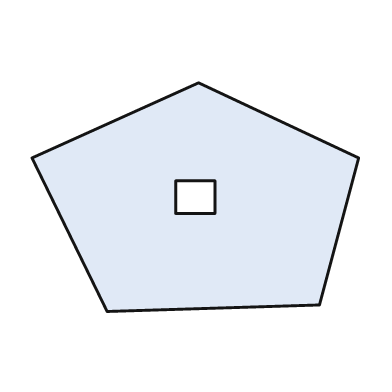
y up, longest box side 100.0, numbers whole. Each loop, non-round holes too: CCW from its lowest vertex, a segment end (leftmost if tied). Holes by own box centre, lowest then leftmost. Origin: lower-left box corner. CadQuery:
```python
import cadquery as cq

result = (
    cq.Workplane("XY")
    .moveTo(23.0, 0.0)
    .lineTo(88.0, 2.0)
    .lineTo(100.0, 47.0)
    .lineTo(51.0, 70.0)
    .lineTo(0.0, 47.0)
    .close()
    .moveTo(44.0, 30.0)
    .lineTo(56.0, 30.0)
    .lineTo(56.0, 40.0)
    .lineTo(44.0, 40.0)
    .close()
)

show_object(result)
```